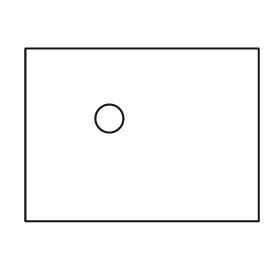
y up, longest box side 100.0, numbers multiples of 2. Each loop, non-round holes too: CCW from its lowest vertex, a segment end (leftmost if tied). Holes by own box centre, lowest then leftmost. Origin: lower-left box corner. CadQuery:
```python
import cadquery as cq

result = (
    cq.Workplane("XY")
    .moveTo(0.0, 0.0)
    .lineTo(100.0, 0.0)
    .lineTo(100.0, 74.0)
    .lineTo(0.0, 74.0)
    .close()
    .moveTo(36.0, 44.0)
    .circle(6.0)
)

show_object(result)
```